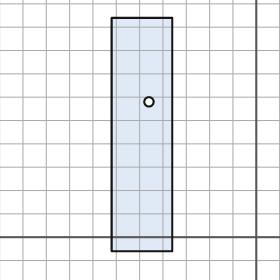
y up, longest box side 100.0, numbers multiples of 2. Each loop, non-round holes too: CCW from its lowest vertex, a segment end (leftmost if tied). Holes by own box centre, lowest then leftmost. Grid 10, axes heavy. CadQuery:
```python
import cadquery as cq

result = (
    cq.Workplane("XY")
    .moveTo(-62.0, -6.0)
    .lineTo(-36.0, -6.0)
    .lineTo(-36.0, 94.0)
    .lineTo(-62.0, 94.0)
    .close()
    .moveTo(-46.0, 58.0)
    .circle(2.0)
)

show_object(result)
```